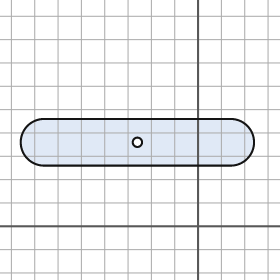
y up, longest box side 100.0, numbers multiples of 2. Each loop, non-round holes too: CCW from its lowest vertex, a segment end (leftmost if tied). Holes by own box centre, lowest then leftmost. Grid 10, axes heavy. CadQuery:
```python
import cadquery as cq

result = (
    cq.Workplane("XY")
    .moveTo(-66.0, 26.0)
    .lineTo(14.0, 26.0)
    .threePointArc((24.0, 36.0), (14.0, 46.0))
    .lineTo(-66.0, 46.0)
    .threePointArc((-76.0, 36.0), (-66.0, 26.0))
    .close()
    .moveTo(-26.0, 36.0)
    .circle(2.0)
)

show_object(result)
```